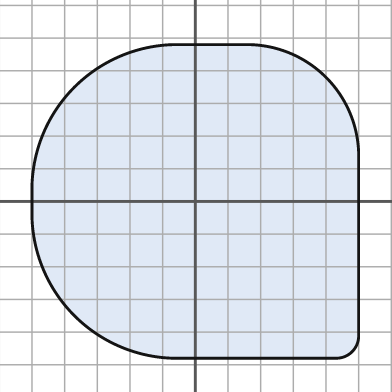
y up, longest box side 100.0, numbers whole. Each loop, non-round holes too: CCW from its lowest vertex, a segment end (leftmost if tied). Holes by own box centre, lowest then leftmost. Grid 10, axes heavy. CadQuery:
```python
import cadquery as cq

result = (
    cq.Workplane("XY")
    .moveTo(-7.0, -48.0)
    .lineTo(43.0, -48.0)
    .threePointArc((48.0, -46.0), (50.0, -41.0))
    .lineTo(50.0, 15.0)
    .threePointArc((40.0, 38.0), (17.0, 48.0))
    .lineTo(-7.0, 48.0)
    .threePointArc((-37.0, 35.0), (-50.0, 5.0))
    .lineTo(-50.0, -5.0)
    .threePointArc((-37.0, -35.0), (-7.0, -48.0))
    .close()
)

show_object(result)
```